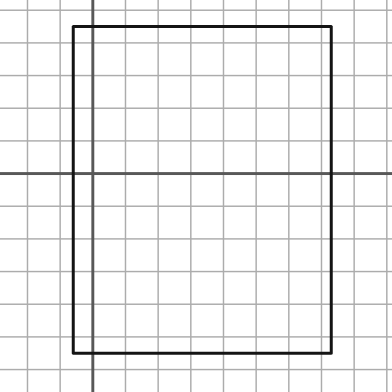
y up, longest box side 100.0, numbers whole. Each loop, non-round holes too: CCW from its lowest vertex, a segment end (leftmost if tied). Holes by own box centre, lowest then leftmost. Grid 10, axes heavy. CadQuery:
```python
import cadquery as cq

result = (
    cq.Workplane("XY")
    .moveTo(-6.0, -55.0)
    .lineTo(73.0, -55.0)
    .lineTo(73.0, 45.0)
    .lineTo(-6.0, 45.0)
    .close()
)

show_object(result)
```